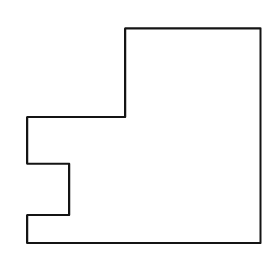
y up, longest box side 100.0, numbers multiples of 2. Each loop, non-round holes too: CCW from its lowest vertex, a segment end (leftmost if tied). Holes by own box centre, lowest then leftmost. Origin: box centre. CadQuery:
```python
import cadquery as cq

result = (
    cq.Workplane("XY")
    .moveTo(-50.0, -46.0)
    .lineTo(50.0, -46.0)
    .lineTo(50.0, 46.0)
    .lineTo(-8.0, 46.0)
    .lineTo(-8.0, 8.0)
    .lineTo(-50.0, 8.0)
    .lineTo(-50.0, -12.0)
    .lineTo(-32.0, -12.0)
    .lineTo(-32.0, -34.0)
    .lineTo(-50.0, -34.0)
    .close()
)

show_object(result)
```